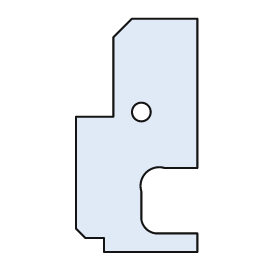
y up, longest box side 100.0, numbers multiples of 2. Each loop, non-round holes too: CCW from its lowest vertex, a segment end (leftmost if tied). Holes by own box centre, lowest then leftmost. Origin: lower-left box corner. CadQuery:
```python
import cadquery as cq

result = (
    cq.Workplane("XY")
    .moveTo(12.0, 0.0)
    .lineTo(52.0, 0.0)
    .lineTo(52.0, 8.0)
    .lineTo(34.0, 8.0)
    .threePointArc((30.0, 10.0), (28.0, 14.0))
    .lineTo(28.0, 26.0)
    .threePointArc((30.0, 34.0), (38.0, 36.0))
    .lineTo(52.0, 36.0)
    .lineTo(52.0, 100.0)
    .lineTo(24.0, 100.0)
    .lineTo(16.0, 92.0)
    .lineTo(16.0, 58.0)
    .lineTo(0.0, 58.0)
    .lineTo(0.0, 10.0)
    .lineTo(4.0, 6.0)
    .lineTo(12.0, 6.0)
    .close()
    .moveTo(28.0, 60.0)
    .circle(4.0)
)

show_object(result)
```